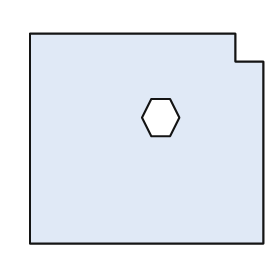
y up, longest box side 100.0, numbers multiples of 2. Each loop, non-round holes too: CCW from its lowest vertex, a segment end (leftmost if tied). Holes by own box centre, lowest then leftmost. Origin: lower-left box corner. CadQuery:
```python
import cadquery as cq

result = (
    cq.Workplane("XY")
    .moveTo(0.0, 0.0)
    .lineTo(100.0, 0.0)
    .lineTo(100.0, 78.0)
    .lineTo(88.0, 78.0)
    .lineTo(88.0, 90.0)
    .lineTo(0.0, 90.0)
    .close()
    .moveTo(52.0, 46.0)
    .lineTo(60.0, 46.0)
    .lineTo(64.0, 54.0)
    .lineTo(60.0, 62.0)
    .lineTo(52.0, 62.0)
    .lineTo(48.0, 54.0)
    .close()
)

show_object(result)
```